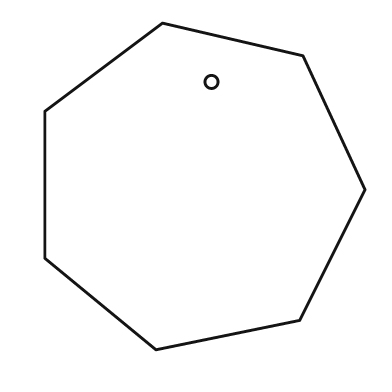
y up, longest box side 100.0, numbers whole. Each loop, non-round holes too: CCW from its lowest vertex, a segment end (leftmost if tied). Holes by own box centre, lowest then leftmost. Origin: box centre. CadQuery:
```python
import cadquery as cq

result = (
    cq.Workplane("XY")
    .moveTo(-15.0, -50.0)
    .lineTo(29.0, -41.0)
    .lineTo(49.0, -1.0)
    .lineTo(30.0, 40.0)
    .lineTo(-13.0, 50.0)
    .lineTo(-49.0, 23.0)
    .lineTo(-49.0, -22.0)
    .close()
    .moveTo(2.0, 32.0)
    .circle(2.0)
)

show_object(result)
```